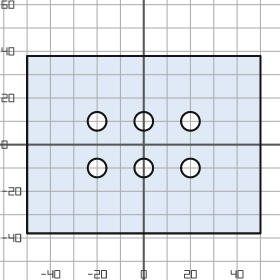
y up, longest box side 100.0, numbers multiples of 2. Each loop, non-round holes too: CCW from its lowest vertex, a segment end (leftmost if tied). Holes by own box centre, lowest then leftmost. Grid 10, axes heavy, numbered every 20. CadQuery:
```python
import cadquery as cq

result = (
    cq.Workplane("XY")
    .moveTo(-50.0, -38.0)
    .lineTo(50.0, -38.0)
    .lineTo(50.0, 38.0)
    .lineTo(-50.0, 38.0)
    .close()
    .moveTo(-20.0, -10.0)
    .circle(4.0)
    .moveTo(0.0, -10.0)
    .circle(4.0)
    .moveTo(20.0, -10.0)
    .circle(4.0)
    .moveTo(-20.0, 10.0)
    .circle(4.0)
    .moveTo(0.0, 10.0)
    .circle(4.0)
    .moveTo(20.0, 10.0)
    .circle(4.0)
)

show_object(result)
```